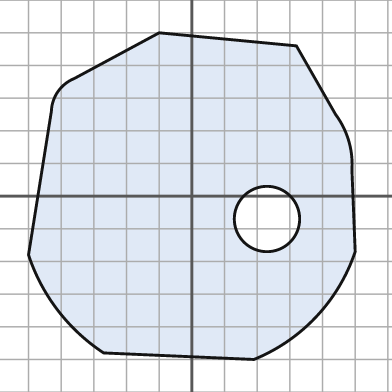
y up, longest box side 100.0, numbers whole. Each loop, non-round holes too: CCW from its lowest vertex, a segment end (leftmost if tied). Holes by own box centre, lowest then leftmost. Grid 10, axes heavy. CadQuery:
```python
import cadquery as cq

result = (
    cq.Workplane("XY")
    .moveTo(19.0, -50.0)
    .threePointArc((38.0, -37.0), (50.0, -17.0))
    .lineTo(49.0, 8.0)
    .threePointArc((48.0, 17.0), (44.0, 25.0))
    .lineTo(32.0, 46.0)
    .lineTo(-10.0, 50.0)
    .lineTo(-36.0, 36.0)
    .threePointArc((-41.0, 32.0), (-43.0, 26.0))
    .lineTo(-50.0, -18.0)
    .threePointArc((-41.0, -35.0), (-27.0, -48.0))
    .close()
    .moveTo(23.0, -7.0)
    .circle(10.0)
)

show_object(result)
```